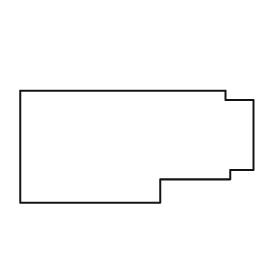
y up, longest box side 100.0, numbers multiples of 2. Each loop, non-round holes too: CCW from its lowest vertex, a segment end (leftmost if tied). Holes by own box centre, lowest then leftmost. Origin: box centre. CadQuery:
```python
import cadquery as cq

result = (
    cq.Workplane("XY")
    .moveTo(-50.0, -24.0)
    .lineTo(10.0, -24.0)
    .lineTo(10.0, -14.0)
    .lineTo(40.0, -14.0)
    .lineTo(40.0, -10.0)
    .lineTo(50.0, -10.0)
    .lineTo(50.0, 20.0)
    .lineTo(38.0, 20.0)
    .lineTo(38.0, 24.0)
    .lineTo(-50.0, 24.0)
    .close()
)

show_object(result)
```